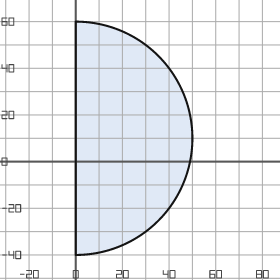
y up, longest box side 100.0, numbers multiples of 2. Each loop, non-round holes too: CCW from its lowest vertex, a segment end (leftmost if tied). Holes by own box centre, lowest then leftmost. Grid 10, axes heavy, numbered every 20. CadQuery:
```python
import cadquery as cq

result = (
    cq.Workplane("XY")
    .moveTo(0.0, -40.0)
    .threePointArc((50.0, 10.0), (0.0, 60.0))
    .close()
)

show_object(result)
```